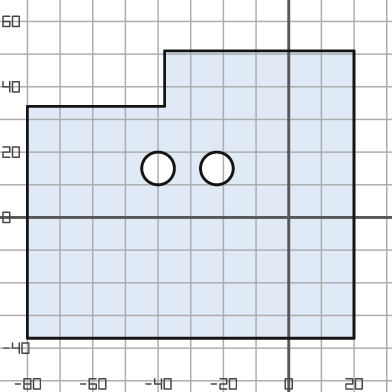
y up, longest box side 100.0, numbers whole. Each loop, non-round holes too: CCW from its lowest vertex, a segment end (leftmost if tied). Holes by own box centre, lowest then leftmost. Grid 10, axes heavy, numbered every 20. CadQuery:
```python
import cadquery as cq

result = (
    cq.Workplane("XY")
    .moveTo(-80.0, -37.0)
    .lineTo(20.0, -37.0)
    .lineTo(20.0, 51.0)
    .lineTo(-38.0, 51.0)
    .lineTo(-38.0, 34.0)
    .lineTo(-80.0, 34.0)
    .close()
    .moveTo(-40.0, 15.0)
    .circle(5.0)
    .moveTo(-22.0, 15.0)
    .circle(5.0)
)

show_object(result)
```